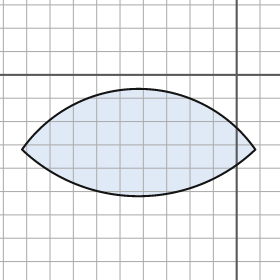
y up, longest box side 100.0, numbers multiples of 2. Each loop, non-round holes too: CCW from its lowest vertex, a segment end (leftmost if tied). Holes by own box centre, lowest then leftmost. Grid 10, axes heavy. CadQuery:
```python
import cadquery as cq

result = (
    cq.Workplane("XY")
    .moveTo(-92.0, -32.0)
    .threePointArc((-42.0, -52.0), (8.0, -32.0))
    .threePointArc((-42.0, -6.0), (-92.0, -32.0))
    .close()
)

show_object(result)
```